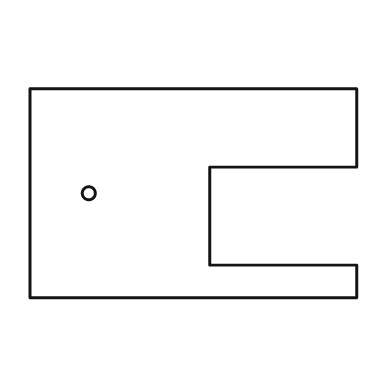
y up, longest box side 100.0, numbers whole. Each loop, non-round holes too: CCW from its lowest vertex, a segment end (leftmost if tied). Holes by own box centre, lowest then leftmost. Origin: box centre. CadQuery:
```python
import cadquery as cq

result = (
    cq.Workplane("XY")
    .moveTo(-50.0, -32.0)
    .lineTo(50.0, -32.0)
    .lineTo(50.0, -22.0)
    .lineTo(5.0, -22.0)
    .lineTo(5.0, 8.0)
    .lineTo(50.0, 8.0)
    .lineTo(50.0, 32.0)
    .lineTo(-50.0, 32.0)
    .close()
    .moveTo(-32.0, 0.0)
    .circle(2.0)
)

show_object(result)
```